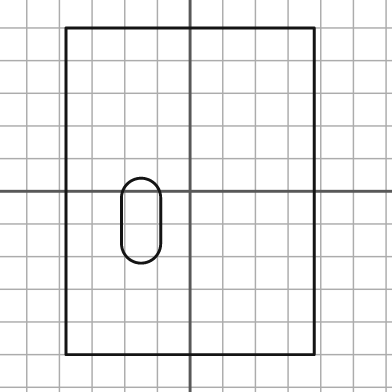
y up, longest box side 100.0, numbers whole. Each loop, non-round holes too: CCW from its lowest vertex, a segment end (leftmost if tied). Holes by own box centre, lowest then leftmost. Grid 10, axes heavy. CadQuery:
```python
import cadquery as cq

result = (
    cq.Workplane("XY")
    .moveTo(-38.0, -50.0)
    .lineTo(38.0, -50.0)
    .lineTo(38.0, 50.0)
    .lineTo(-38.0, 50.0)
    .close()
    .moveTo(-21.0, -16.0)
    .threePointArc((-15.0, -22.0), (-9.0, -16.0))
    .lineTo(-9.0, -2.0)
    .threePointArc((-15.0, 4.0), (-21.0, -2.0))
    .close()
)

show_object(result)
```